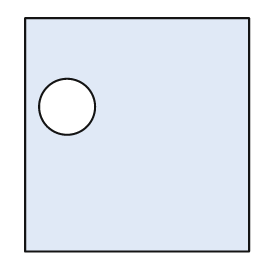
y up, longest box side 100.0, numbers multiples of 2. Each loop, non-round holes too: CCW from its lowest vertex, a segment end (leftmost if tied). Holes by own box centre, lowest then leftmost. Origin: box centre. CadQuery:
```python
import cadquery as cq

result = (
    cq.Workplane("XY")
    .moveTo(-48.0, -50.0)
    .lineTo(48.0, -50.0)
    .lineTo(48.0, 50.0)
    .lineTo(-48.0, 50.0)
    .close()
    .moveTo(-30.0, 12.0)
    .circle(12.0)
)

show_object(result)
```